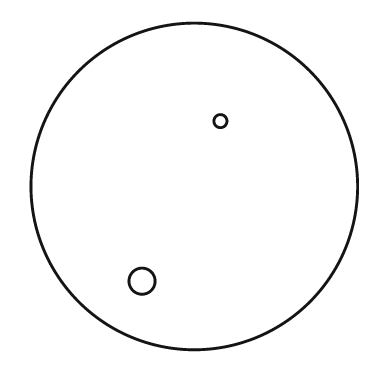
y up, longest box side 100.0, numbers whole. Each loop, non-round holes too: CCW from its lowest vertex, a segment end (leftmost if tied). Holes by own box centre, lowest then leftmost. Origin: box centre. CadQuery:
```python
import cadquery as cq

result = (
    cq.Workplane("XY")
    .moveTo(0.0, 0.0)
    .circle(50.0)
    .moveTo(-16.0, -29.0)
    .circle(4.0)
    .moveTo(8.0, 20.0)
    .circle(2.0)
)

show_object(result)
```